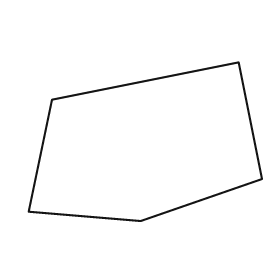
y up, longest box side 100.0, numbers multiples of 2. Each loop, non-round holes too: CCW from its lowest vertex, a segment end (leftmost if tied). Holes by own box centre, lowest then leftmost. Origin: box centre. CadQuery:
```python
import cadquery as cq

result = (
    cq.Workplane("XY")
    .moveTo(-2.0, -34.0)
    .lineTo(50.0, -16.0)
    .lineTo(40.0, 34.0)
    .lineTo(-40.0, 18.0)
    .lineTo(-50.0, -30.0)
    .close()
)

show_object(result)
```